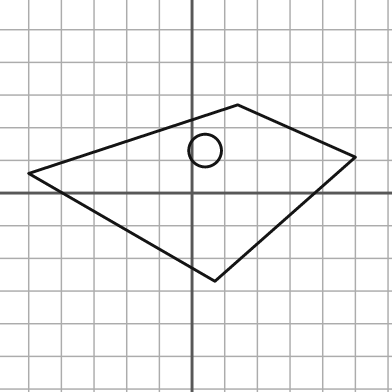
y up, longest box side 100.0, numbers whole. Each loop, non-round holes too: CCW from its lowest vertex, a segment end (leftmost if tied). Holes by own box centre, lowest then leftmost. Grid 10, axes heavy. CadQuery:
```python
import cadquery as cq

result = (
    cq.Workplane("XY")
    .moveTo(7.0, -27.0)
    .lineTo(50.0, 11.0)
    .lineTo(14.0, 27.0)
    .lineTo(-50.0, 6.0)
    .close()
    .moveTo(4.0, 13.0)
    .circle(5.0)
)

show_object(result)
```